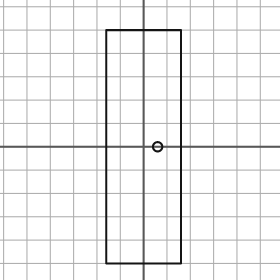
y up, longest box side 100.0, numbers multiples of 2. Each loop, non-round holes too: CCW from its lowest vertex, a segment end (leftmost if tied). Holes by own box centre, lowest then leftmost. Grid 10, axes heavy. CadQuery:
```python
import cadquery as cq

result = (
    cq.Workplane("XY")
    .moveTo(-16.0, -50.0)
    .lineTo(16.0, -50.0)
    .lineTo(16.0, 50.0)
    .lineTo(-16.0, 50.0)
    .close()
    .moveTo(6.0, 0.0)
    .circle(2.0)
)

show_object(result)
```